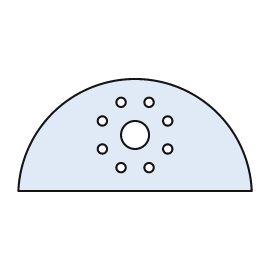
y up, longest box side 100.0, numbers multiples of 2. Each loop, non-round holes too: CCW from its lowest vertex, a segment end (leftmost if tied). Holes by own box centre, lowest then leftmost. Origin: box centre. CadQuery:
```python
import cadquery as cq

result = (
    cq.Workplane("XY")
    .moveTo(-50.0, -24.0)
    .lineTo(50.0, -24.0)
    .threePointArc((0.0, 24.0), (-50.0, -24.0))
    .close()
    .moveTo(-6.0, -14.0)
    .circle(2.0)
    .moveTo(6.0, -14.0)
    .circle(2.0)
    .moveTo(-14.0, -6.0)
    .circle(2.0)
    .moveTo(14.0, -6.0)
    .circle(2.0)
    .moveTo(0.0, 0.0)
    .circle(6.0)
    .moveTo(-14.0, 6.0)
    .circle(2.0)
    .moveTo(14.0, 6.0)
    .circle(2.0)
    .moveTo(-6.0, 14.0)
    .circle(2.0)
    .moveTo(6.0, 14.0)
    .circle(2.0)
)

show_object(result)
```